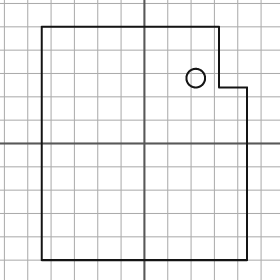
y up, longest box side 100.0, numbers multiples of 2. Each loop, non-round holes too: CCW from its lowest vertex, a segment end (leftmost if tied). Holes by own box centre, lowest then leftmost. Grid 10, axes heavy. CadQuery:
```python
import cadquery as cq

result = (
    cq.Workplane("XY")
    .moveTo(-44.0, -50.0)
    .lineTo(44.0, -50.0)
    .lineTo(44.0, 24.0)
    .lineTo(32.0, 24.0)
    .lineTo(32.0, 50.0)
    .lineTo(-44.0, 50.0)
    .close()
    .moveTo(22.0, 28.0)
    .circle(4.0)
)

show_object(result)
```